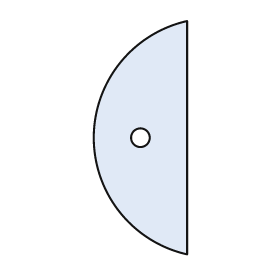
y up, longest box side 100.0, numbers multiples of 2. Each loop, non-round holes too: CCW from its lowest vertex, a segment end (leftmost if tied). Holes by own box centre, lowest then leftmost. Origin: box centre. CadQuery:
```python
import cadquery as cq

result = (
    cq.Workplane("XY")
    .moveTo(20.0, -50.0)
    .lineTo(20.0, 50.0)
    .threePointArc((-20.0, 0.0), (20.0, -50.0))
    .close()
    .moveTo(0.0, 0.0)
    .circle(4.0)
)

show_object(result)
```